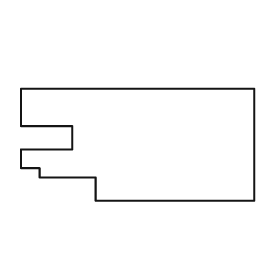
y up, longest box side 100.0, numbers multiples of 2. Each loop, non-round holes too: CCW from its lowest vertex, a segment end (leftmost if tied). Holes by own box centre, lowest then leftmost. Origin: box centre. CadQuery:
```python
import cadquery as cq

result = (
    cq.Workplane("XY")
    .moveTo(-18.0, -24.0)
    .lineTo(50.0, -24.0)
    .lineTo(50.0, 24.0)
    .lineTo(-50.0, 24.0)
    .lineTo(-50.0, 8.0)
    .lineTo(-28.0, 8.0)
    .lineTo(-28.0, -2.0)
    .lineTo(-50.0, -2.0)
    .lineTo(-50.0, -10.0)
    .lineTo(-42.0, -10.0)
    .lineTo(-42.0, -14.0)
    .lineTo(-18.0, -14.0)
    .close()
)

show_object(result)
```